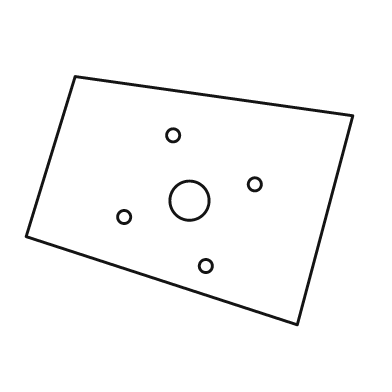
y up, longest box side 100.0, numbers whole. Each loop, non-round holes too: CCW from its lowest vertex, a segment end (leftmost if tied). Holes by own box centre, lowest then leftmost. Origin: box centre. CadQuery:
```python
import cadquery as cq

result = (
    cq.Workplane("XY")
    .moveTo(33.0, -38.0)
    .lineTo(50.0, 26.0)
    .lineTo(-35.0, 38.0)
    .lineTo(-50.0, -11.0)
    .close()
    .moveTo(5.0, -20.0)
    .circle(2.0)
    .moveTo(-20.0, -5.0)
    .circle(2.0)
    .moveTo(0.0, 0.0)
    .circle(6.0)
    .moveTo(20.0, 5.0)
    .circle(2.0)
    .moveTo(-5.0, 20.0)
    .circle(2.0)
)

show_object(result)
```